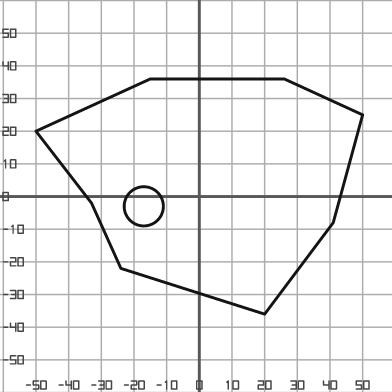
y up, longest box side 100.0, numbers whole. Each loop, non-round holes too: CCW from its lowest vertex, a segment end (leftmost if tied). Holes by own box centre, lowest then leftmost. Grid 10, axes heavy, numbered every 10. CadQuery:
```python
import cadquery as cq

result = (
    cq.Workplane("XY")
    .moveTo(20.0, -36.0)
    .lineTo(41.0, -8.0)
    .lineTo(50.0, 25.0)
    .lineTo(26.0, 36.0)
    .lineTo(-15.0, 36.0)
    .lineTo(-50.0, 20.0)
    .lineTo(-33.0, -2.0)
    .lineTo(-24.0, -22.0)
    .close()
    .moveTo(-17.0, -3.0)
    .circle(6.0)
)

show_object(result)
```